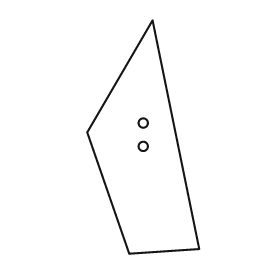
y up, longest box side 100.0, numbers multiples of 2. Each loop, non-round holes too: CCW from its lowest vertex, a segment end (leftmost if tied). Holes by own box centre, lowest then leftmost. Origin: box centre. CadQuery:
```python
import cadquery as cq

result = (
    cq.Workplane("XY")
    .moveTo(-6.0, -50.0)
    .lineTo(24.0, -48.0)
    .lineTo(4.0, 50.0)
    .lineTo(-24.0, 2.0)
    .close()
    .moveTo(0.0, -4.0)
    .circle(2.0)
    .moveTo(0.0, 6.0)
    .circle(2.0)
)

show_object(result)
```